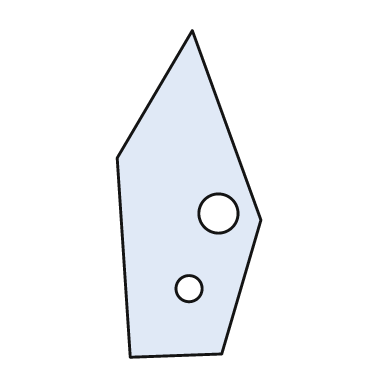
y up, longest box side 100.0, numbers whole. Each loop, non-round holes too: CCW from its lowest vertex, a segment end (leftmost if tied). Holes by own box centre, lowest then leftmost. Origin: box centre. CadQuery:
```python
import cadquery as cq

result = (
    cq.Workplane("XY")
    .moveTo(-18.0, -50.0)
    .lineTo(10.0, -49.0)
    .lineTo(22.0, -8.0)
    .lineTo(1.0, 50.0)
    .lineTo(-22.0, 11.0)
    .close()
    .moveTo(0.0, -29.0)
    .circle(4.0)
    .moveTo(9.0, -6.0)
    .circle(6.0)
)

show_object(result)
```